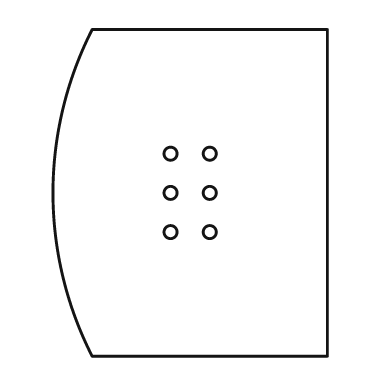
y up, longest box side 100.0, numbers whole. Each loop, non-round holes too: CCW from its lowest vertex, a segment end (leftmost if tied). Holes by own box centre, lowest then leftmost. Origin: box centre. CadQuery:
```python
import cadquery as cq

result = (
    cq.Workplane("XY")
    .moveTo(-30.0, -50.0)
    .lineTo(42.0, -50.0)
    .lineTo(42.0, 50.0)
    .lineTo(-30.0, 50.0)
    .threePointArc((-42.0, 0.0), (-30.0, -50.0))
    .close()
    .moveTo(-6.0, -12.0)
    .circle(2.0)
    .moveTo(6.0, -12.0)
    .circle(2.0)
    .moveTo(-6.0, 0.0)
    .circle(2.0)
    .moveTo(6.0, 0.0)
    .circle(2.0)
    .moveTo(-6.0, 12.0)
    .circle(2.0)
    .moveTo(6.0, 12.0)
    .circle(2.0)
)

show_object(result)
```